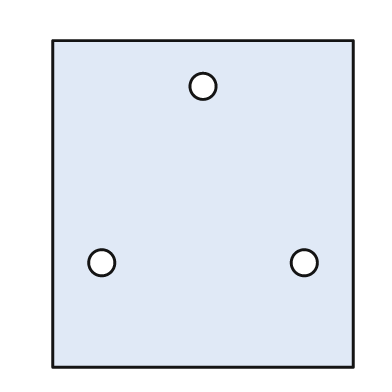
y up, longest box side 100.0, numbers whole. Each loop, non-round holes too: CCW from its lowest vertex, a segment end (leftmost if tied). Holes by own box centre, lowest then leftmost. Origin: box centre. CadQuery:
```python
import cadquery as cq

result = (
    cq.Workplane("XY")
    .moveTo(-46.0, -50.0)
    .lineTo(46.0, -50.0)
    .lineTo(46.0, 50.0)
    .lineTo(-46.0, 50.0)
    .close()
    .moveTo(-31.0, -18.0)
    .circle(4.0)
    .moveTo(31.0, -18.0)
    .circle(4.0)
    .moveTo(0.0, 36.0)
    .circle(4.0)
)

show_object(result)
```